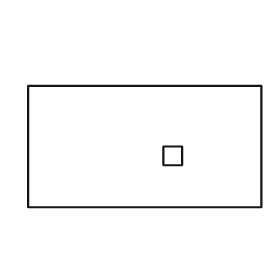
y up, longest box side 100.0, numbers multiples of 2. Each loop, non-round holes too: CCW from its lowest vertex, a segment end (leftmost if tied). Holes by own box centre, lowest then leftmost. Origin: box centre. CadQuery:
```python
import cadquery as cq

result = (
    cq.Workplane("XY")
    .moveTo(-50.0, -26.0)
    .lineTo(50.0, -26.0)
    .lineTo(50.0, 26.0)
    .lineTo(-50.0, 26.0)
    .close()
    .moveTo(8.0, -8.0)
    .lineTo(16.0, -8.0)
    .lineTo(16.0, 0.0)
    .lineTo(8.0, 0.0)
    .close()
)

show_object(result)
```